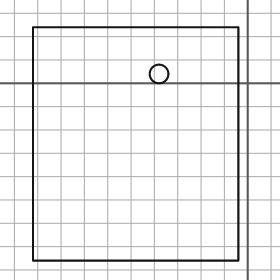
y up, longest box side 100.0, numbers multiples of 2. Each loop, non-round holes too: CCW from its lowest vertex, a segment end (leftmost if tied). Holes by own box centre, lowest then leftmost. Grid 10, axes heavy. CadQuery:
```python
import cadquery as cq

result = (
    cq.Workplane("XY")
    .moveTo(-92.0, -76.0)
    .lineTo(-4.0, -76.0)
    .lineTo(-4.0, 24.0)
    .lineTo(-92.0, 24.0)
    .close()
    .moveTo(-38.0, 4.0)
    .circle(4.0)
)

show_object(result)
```